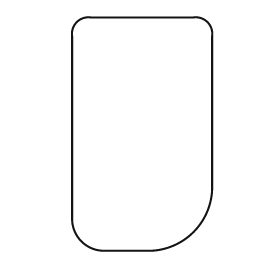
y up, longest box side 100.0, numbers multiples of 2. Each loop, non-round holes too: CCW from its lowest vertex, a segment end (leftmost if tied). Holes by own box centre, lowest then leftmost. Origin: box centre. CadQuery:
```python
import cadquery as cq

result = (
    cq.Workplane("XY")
    .moveTo(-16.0, -50.0)
    .lineTo(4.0, -50.0)
    .threePointArc((22.0, -42.0), (30.0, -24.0))
    .lineTo(30.0, 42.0)
    .threePointArc((28.0, 48.0), (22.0, 50.0))
    .lineTo(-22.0, 50.0)
    .threePointArc((-28.0, 48.0), (-30.0, 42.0))
    .lineTo(-30.0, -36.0)
    .threePointArc((-26.0, -46.0), (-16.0, -50.0))
    .close()
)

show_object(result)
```